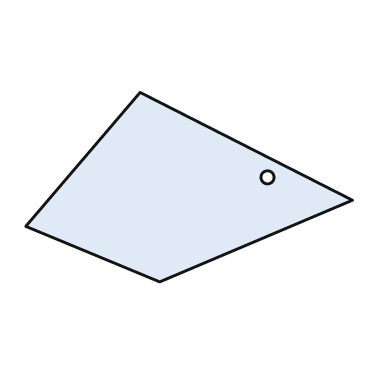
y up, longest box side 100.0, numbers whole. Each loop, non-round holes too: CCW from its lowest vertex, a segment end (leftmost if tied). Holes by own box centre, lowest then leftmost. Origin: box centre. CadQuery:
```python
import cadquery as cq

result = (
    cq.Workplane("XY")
    .moveTo(-9.0, -29.0)
    .lineTo(50.0, -4.0)
    .lineTo(-15.0, 29.0)
    .lineTo(-50.0, -12.0)
    .close()
    .moveTo(24.0, 3.0)
    .circle(2.0)
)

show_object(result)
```